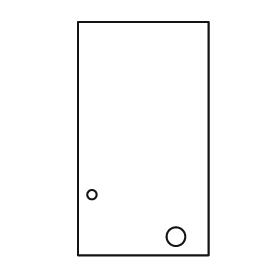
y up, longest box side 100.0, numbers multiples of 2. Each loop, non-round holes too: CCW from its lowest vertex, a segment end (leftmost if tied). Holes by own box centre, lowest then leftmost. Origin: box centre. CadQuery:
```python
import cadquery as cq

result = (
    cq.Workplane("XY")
    .moveTo(-28.0, -50.0)
    .lineTo(28.0, -50.0)
    .lineTo(28.0, 50.0)
    .lineTo(-28.0, 50.0)
    .close()
    .moveTo(14.0, -42.0)
    .circle(4.0)
    .moveTo(-22.0, -24.0)
    .circle(2.0)
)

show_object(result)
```